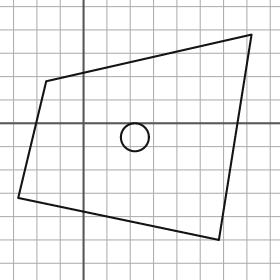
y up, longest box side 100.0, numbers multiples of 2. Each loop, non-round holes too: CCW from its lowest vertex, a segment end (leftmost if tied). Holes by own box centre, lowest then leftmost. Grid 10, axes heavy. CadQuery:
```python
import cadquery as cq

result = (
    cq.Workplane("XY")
    .moveTo(58.0, -50.0)
    .lineTo(72.0, 38.0)
    .lineTo(-16.0, 18.0)
    .lineTo(-28.0, -32.0)
    .close()
    .moveTo(22.0, -6.0)
    .circle(6.0)
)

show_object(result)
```